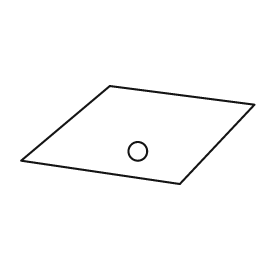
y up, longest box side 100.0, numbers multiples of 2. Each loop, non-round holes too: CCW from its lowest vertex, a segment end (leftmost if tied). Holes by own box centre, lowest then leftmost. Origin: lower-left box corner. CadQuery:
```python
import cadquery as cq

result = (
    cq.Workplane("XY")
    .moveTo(68.0, 0.0)
    .lineTo(100.0, 34.0)
    .lineTo(38.0, 42.0)
    .lineTo(0.0, 10.0)
    .close()
    .moveTo(50.0, 14.0)
    .circle(4.0)
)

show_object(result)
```